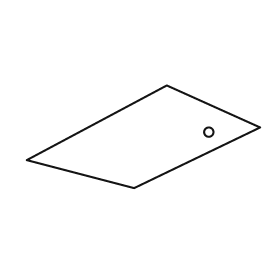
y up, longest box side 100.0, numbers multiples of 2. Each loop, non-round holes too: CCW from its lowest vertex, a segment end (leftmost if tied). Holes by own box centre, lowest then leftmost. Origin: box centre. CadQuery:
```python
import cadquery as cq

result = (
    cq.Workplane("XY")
    .moveTo(-4.0, -22.0)
    .lineTo(50.0, 4.0)
    .lineTo(10.0, 22.0)
    .lineTo(-50.0, -10.0)
    .close()
    .moveTo(28.0, 2.0)
    .circle(2.0)
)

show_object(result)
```